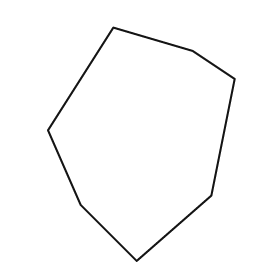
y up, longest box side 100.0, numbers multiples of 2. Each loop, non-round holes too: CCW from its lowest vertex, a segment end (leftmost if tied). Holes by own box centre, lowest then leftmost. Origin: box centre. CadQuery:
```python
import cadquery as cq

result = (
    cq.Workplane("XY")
    .moveTo(-2.0, -50.0)
    .lineTo(30.0, -22.0)
    .lineTo(40.0, 28.0)
    .lineTo(22.0, 40.0)
    .lineTo(-12.0, 50.0)
    .lineTo(-40.0, 6.0)
    .lineTo(-26.0, -26.0)
    .close()
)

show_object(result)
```